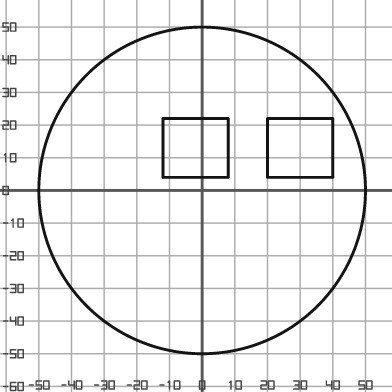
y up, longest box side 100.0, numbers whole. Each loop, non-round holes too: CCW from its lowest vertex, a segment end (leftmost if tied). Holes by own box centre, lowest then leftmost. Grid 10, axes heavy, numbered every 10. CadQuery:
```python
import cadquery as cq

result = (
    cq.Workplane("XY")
    .moveTo(0.0, 0.0)
    .circle(50.0)
    .moveTo(-12.0, 4.0)
    .lineTo(8.0, 4.0)
    .lineTo(8.0, 22.0)
    .lineTo(-12.0, 22.0)
    .close()
    .moveTo(20.0, 4.0)
    .lineTo(40.0, 4.0)
    .lineTo(40.0, 22.0)
    .lineTo(20.0, 22.0)
    .close()
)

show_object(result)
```